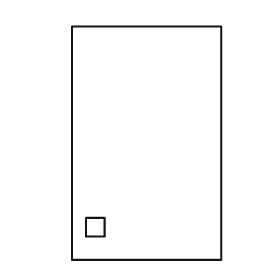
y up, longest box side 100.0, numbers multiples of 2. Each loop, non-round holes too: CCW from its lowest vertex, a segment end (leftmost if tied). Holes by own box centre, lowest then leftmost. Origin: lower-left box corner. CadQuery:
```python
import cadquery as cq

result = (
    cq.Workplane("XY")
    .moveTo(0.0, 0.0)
    .lineTo(64.0, 0.0)
    .lineTo(64.0, 100.0)
    .lineTo(0.0, 100.0)
    .close()
    .moveTo(6.0, 10.0)
    .lineTo(14.0, 10.0)
    .lineTo(14.0, 18.0)
    .lineTo(6.0, 18.0)
    .close()
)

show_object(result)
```